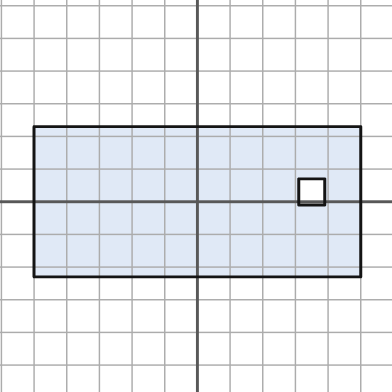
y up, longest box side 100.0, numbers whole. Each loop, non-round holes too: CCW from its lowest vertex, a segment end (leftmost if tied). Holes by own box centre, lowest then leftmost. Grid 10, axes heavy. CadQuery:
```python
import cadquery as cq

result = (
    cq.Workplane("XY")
    .moveTo(-50.0, -23.0)
    .lineTo(50.0, -23.0)
    .lineTo(50.0, 23.0)
    .lineTo(-50.0, 23.0)
    .close()
    .moveTo(31.0, -1.0)
    .lineTo(39.0, -1.0)
    .lineTo(39.0, 7.0)
    .lineTo(31.0, 7.0)
    .close()
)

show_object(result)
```